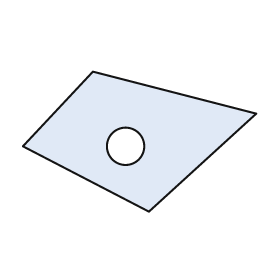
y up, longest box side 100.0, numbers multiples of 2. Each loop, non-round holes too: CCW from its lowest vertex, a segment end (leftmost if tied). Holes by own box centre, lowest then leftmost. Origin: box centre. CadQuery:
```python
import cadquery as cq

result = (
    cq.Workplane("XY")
    .moveTo(4.0, -30.0)
    .lineTo(50.0, 12.0)
    .lineTo(-20.0, 30.0)
    .lineTo(-50.0, -2.0)
    .close()
    .moveTo(-6.0, -2.0)
    .circle(8.0)
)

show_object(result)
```